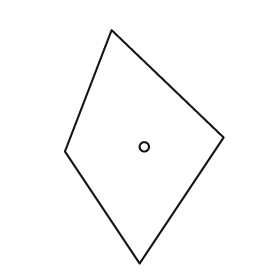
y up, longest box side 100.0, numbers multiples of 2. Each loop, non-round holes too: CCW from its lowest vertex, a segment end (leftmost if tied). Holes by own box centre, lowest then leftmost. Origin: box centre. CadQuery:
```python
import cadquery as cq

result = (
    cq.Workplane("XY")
    .moveTo(-2.0, -50.0)
    .lineTo(34.0, 4.0)
    .lineTo(-14.0, 50.0)
    .lineTo(-34.0, -2.0)
    .close()
    .moveTo(0.0, 0.0)
    .circle(2.0)
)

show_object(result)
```